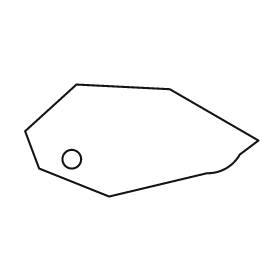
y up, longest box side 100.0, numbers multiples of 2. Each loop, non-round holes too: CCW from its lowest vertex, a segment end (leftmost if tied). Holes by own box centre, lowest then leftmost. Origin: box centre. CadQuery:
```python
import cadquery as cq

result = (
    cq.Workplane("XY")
    .moveTo(-14.0, -24.0)
    .lineTo(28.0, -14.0)
    .threePointArc((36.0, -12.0), (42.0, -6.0))
    .lineTo(50.0, 0.0)
    .lineTo(12.0, 22.0)
    .lineTo(-28.0, 24.0)
    .lineTo(-50.0, 4.0)
    .lineTo(-44.0, -12.0)
    .close()
    .moveTo(-30.0, -8.0)
    .circle(4.0)
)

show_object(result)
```